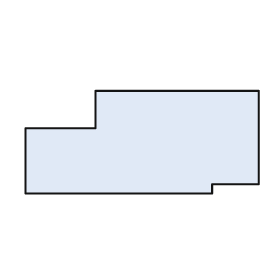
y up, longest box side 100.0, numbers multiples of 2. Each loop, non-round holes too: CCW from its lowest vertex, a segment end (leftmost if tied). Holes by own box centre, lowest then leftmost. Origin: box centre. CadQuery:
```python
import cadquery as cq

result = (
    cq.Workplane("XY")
    .moveTo(-50.0, -22.0)
    .lineTo(30.0, -22.0)
    .lineTo(30.0, -18.0)
    .lineTo(50.0, -18.0)
    .lineTo(50.0, 22.0)
    .lineTo(-20.0, 22.0)
    .lineTo(-20.0, 6.0)
    .lineTo(-50.0, 6.0)
    .close()
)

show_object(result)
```